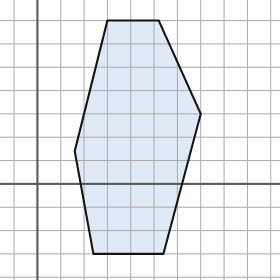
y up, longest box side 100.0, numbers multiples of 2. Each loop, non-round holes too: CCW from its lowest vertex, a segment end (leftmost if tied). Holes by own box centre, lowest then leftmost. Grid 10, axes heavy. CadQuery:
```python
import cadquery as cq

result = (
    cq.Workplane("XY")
    .moveTo(24.0, -30.0)
    .lineTo(54.0, -30.0)
    .lineTo(70.0, 30.0)
    .lineTo(52.0, 70.0)
    .lineTo(30.0, 70.0)
    .lineTo(16.0, 14.0)
    .close()
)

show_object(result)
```